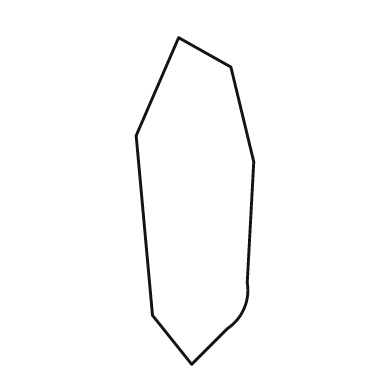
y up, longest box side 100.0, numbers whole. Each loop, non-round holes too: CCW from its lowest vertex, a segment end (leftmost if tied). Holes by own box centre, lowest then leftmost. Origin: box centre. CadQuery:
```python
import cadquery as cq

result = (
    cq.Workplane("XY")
    .moveTo(-1.0, -50.0)
    .lineTo(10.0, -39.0)
    .threePointArc((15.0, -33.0), (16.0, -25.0))
    .lineTo(18.0, 12.0)
    .lineTo(11.0, 41.0)
    .lineTo(-5.0, 50.0)
    .lineTo(-18.0, 20.0)
    .lineTo(-13.0, -35.0)
    .close()
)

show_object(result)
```